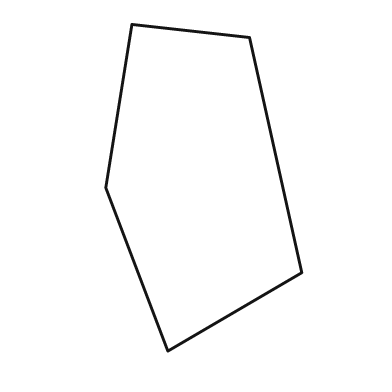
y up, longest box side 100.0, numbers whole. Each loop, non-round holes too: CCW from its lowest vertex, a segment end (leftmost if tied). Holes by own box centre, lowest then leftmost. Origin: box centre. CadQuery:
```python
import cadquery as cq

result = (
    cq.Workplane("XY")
    .moveTo(-11.0, -50.0)
    .lineTo(30.0, -26.0)
    .lineTo(14.0, 46.0)
    .lineTo(-22.0, 50.0)
    .lineTo(-30.0, 0.0)
    .close()
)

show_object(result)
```